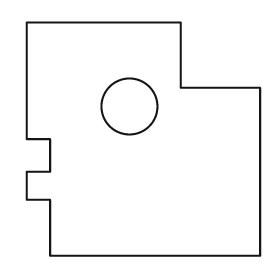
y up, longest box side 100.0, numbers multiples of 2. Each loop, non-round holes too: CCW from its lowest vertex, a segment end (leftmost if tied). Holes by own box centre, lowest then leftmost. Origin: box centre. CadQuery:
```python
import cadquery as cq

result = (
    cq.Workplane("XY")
    .moveTo(-40.0, -50.0)
    .lineTo(50.0, -50.0)
    .lineTo(50.0, 22.0)
    .lineTo(16.0, 22.0)
    .lineTo(16.0, 50.0)
    .lineTo(-50.0, 50.0)
    .lineTo(-50.0, 0.0)
    .lineTo(-40.0, 0.0)
    .lineTo(-40.0, -14.0)
    .lineTo(-50.0, -14.0)
    .lineTo(-50.0, -26.0)
    .lineTo(-40.0, -26.0)
    .close()
    .moveTo(-6.0, 14.0)
    .circle(12.0)
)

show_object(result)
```